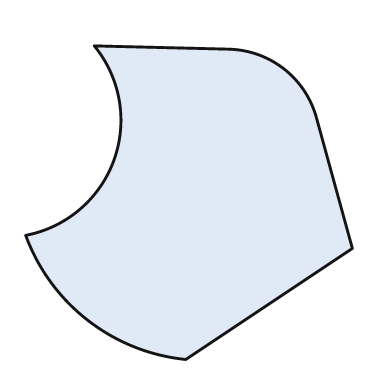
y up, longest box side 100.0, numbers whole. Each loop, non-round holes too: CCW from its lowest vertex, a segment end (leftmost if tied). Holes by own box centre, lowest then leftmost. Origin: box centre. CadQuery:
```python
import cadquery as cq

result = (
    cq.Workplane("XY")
    .moveTo(-1.0, -48.0)
    .lineTo(50.0, -14.0)
    .lineTo(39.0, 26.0)
    .threePointArc((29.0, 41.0), (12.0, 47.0))
    .lineTo(-29.0, 48.0)
    .threePointArc((-23.0, 13.0), (-50.0, -10.0))
    .threePointArc((-31.0, -36.0), (-1.0, -48.0))
    .close()
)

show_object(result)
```